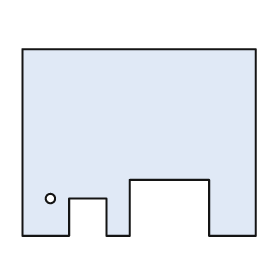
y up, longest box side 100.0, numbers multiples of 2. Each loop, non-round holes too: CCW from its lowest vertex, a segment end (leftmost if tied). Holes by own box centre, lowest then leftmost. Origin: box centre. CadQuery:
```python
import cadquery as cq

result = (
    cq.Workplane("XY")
    .moveTo(-50.0, -40.0)
    .lineTo(-30.0, -40.0)
    .lineTo(-30.0, -24.0)
    .lineTo(-14.0, -24.0)
    .lineTo(-14.0, -40.0)
    .lineTo(-4.0, -40.0)
    .lineTo(-4.0, -16.0)
    .lineTo(30.0, -16.0)
    .lineTo(30.0, -40.0)
    .lineTo(50.0, -40.0)
    .lineTo(50.0, 40.0)
    .lineTo(-50.0, 40.0)
    .close()
    .moveTo(-38.0, -24.0)
    .circle(2.0)
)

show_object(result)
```